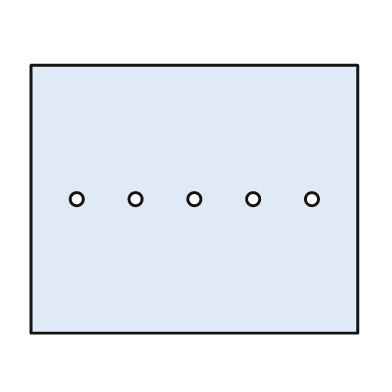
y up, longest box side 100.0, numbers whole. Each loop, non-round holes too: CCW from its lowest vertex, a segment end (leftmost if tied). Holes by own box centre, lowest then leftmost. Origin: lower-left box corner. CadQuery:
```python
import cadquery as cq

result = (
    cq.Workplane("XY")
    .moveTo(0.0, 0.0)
    .lineTo(100.0, 0.0)
    .lineTo(100.0, 82.0)
    .lineTo(0.0, 82.0)
    .close()
    .moveTo(14.0, 41.0)
    .circle(2.0)
    .moveTo(32.0, 41.0)
    .circle(2.0)
    .moveTo(50.0, 41.0)
    .circle(2.0)
    .moveTo(68.0, 41.0)
    .circle(2.0)
    .moveTo(86.0, 41.0)
    .circle(2.0)
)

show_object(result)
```